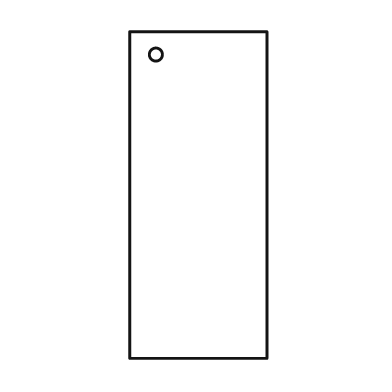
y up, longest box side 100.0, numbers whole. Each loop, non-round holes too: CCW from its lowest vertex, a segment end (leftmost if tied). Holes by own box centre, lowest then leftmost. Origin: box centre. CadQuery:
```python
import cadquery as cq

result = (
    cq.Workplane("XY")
    .moveTo(-21.0, -50.0)
    .lineTo(21.0, -50.0)
    .lineTo(21.0, 50.0)
    .lineTo(-21.0, 50.0)
    .close()
    .moveTo(-13.0, 43.0)
    .circle(2.0)
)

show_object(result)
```